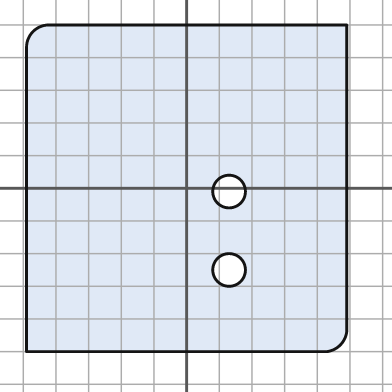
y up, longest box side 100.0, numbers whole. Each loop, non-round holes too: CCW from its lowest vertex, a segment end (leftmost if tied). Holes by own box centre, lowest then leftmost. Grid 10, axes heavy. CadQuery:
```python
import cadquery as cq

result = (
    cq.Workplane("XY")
    .moveTo(-49.0, -50.0)
    .lineTo(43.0, -50.0)
    .threePointArc((47.0, -48.0), (49.0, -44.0))
    .lineTo(49.0, 50.0)
    .lineTo(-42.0, 50.0)
    .threePointArc((-47.0, 48.0), (-49.0, 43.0))
    .close()
    .moveTo(13.0, -25.0)
    .circle(5.0)
    .moveTo(13.0, -1.0)
    .circle(5.0)
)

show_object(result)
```